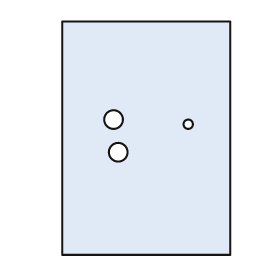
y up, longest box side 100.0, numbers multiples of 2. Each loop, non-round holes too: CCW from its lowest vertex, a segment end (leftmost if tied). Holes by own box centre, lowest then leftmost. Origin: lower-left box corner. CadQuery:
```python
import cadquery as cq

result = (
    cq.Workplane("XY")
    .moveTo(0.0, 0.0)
    .lineTo(72.0, 0.0)
    .lineTo(72.0, 100.0)
    .lineTo(0.0, 100.0)
    .close()
    .moveTo(24.0, 44.0)
    .circle(4.0)
    .moveTo(54.0, 56.0)
    .circle(2.0)
    .moveTo(22.0, 58.0)
    .circle(4.0)
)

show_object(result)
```